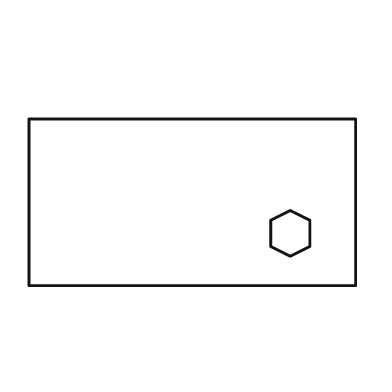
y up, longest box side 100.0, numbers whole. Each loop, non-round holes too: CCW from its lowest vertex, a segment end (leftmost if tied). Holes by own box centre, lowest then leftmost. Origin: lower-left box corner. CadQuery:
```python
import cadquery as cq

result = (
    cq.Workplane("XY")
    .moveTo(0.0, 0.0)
    .lineTo(100.0, 0.0)
    .lineTo(100.0, 51.0)
    .lineTo(0.0, 51.0)
    .close()
    .moveTo(80.0, 9.0)
    .lineTo(86.0, 12.0)
    .lineTo(86.0, 20.0)
    .lineTo(80.0, 23.0)
    .lineTo(74.0, 20.0)
    .lineTo(74.0, 12.0)
    .close()
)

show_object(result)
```